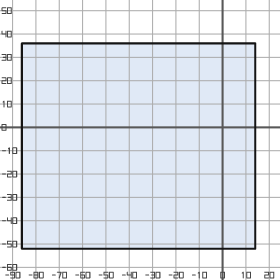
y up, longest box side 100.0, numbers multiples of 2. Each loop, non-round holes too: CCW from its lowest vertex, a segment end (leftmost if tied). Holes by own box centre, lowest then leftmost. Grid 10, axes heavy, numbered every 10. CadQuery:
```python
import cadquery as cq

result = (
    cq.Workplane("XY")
    .moveTo(-86.0, -52.0)
    .lineTo(14.0, -52.0)
    .lineTo(14.0, 36.0)
    .lineTo(-86.0, 36.0)
    .close()
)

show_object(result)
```